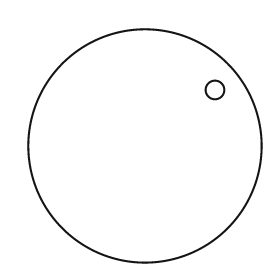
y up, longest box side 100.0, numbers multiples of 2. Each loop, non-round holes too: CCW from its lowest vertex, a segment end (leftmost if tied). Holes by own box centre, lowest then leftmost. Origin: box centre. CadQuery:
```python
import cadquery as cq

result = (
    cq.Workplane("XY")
    .moveTo(0.0, 0.0)
    .circle(50.0)
    .moveTo(30.0, 24.0)
    .circle(4.0)
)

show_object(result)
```